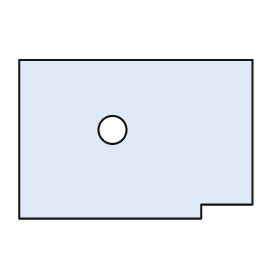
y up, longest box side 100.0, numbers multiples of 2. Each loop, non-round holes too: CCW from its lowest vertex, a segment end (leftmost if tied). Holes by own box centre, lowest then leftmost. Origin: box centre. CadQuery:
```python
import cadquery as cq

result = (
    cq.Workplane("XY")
    .moveTo(-50.0, -34.0)
    .lineTo(28.0, -34.0)
    .lineTo(28.0, -28.0)
    .lineTo(50.0, -28.0)
    .lineTo(50.0, 34.0)
    .lineTo(-50.0, 34.0)
    .close()
    .moveTo(-10.0, 4.0)
    .circle(6.0)
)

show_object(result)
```